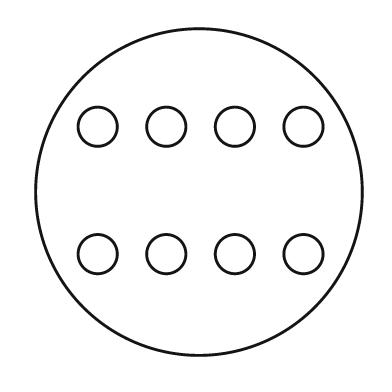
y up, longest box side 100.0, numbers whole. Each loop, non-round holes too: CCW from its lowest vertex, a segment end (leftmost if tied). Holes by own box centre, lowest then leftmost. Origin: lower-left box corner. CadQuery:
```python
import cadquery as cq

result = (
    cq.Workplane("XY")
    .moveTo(50.0, 50.0)
    .circle(50.0)
    .moveTo(19.0, 31.0)
    .circle(6.0)
    .moveTo(40.0, 31.0)
    .circle(6.0)
    .moveTo(61.0, 31.0)
    .circle(6.0)
    .moveTo(82.0, 31.0)
    .circle(6.0)
    .moveTo(19.0, 70.0)
    .circle(6.0)
    .moveTo(40.0, 70.0)
    .circle(6.0)
    .moveTo(61.0, 70.0)
    .circle(6.0)
    .moveTo(82.0, 70.0)
    .circle(6.0)
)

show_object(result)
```